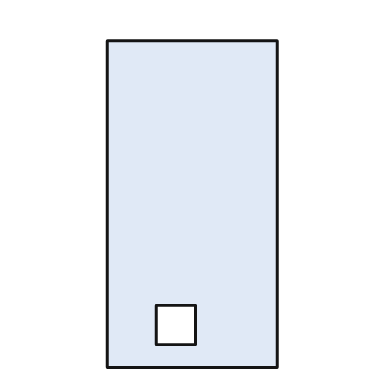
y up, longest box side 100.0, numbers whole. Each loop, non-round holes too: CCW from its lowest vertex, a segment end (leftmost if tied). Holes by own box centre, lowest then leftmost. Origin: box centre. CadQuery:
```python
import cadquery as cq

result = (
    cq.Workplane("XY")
    .moveTo(-26.0, -50.0)
    .lineTo(26.0, -50.0)
    .lineTo(26.0, 50.0)
    .lineTo(-26.0, 50.0)
    .close()
    .moveTo(-11.0, -43.0)
    .lineTo(1.0, -43.0)
    .lineTo(1.0, -31.0)
    .lineTo(-11.0, -31.0)
    .close()
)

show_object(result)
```